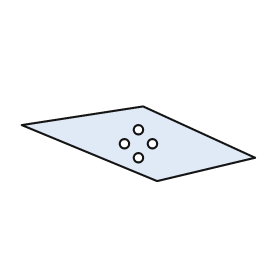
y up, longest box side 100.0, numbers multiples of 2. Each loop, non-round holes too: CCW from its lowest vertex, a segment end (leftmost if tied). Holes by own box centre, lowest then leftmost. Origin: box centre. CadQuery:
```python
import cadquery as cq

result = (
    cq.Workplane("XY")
    .moveTo(8.0, -16.0)
    .lineTo(50.0, -6.0)
    .lineTo(2.0, 16.0)
    .lineTo(-50.0, 8.0)
    .close()
    .moveTo(0.0, -6.0)
    .circle(2.0)
    .moveTo(-6.0, 0.0)
    .circle(2.0)
    .moveTo(6.0, 0.0)
    .circle(2.0)
    .moveTo(0.0, 6.0)
    .circle(2.0)
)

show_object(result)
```